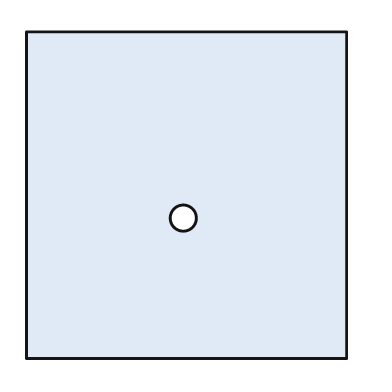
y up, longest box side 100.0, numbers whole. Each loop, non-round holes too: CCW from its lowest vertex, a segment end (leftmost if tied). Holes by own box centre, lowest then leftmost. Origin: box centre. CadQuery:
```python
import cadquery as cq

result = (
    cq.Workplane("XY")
    .moveTo(-49.0, -50.0)
    .lineTo(49.0, -50.0)
    .lineTo(49.0, 50.0)
    .lineTo(-49.0, 50.0)
    .close()
    .moveTo(-1.0, -7.0)
    .circle(4.0)
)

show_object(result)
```